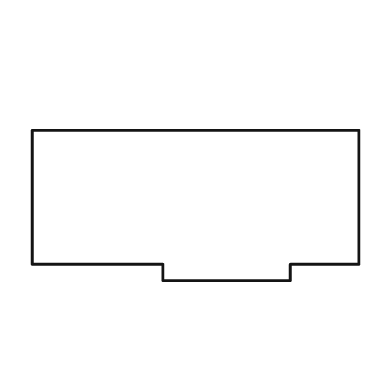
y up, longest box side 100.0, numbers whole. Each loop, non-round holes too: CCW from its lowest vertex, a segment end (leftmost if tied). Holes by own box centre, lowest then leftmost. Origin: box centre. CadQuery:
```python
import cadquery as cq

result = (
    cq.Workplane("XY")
    .moveTo(-10.0, -23.0)
    .lineTo(29.0, -23.0)
    .lineTo(29.0, -18.0)
    .lineTo(50.0, -18.0)
    .lineTo(50.0, 23.0)
    .lineTo(-50.0, 23.0)
    .lineTo(-50.0, -18.0)
    .lineTo(-10.0, -18.0)
    .close()
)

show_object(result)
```